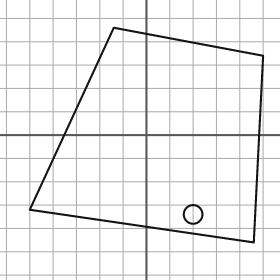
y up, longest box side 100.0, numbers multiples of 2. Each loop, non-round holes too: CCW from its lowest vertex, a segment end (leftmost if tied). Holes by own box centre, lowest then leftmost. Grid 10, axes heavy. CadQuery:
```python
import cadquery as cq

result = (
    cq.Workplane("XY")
    .moveTo(46.0, -46.0)
    .lineTo(50.0, 34.0)
    .lineTo(-14.0, 46.0)
    .lineTo(-50.0, -32.0)
    .close()
    .moveTo(20.0, -34.0)
    .circle(4.0)
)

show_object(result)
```